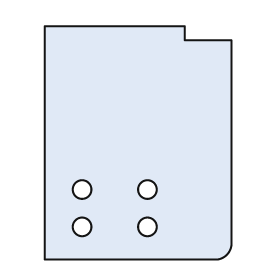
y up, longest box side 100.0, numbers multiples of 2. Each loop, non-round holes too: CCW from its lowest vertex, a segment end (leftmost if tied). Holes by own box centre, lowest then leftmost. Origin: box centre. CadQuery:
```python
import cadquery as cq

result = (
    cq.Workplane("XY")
    .moveTo(-40.0, -50.0)
    .lineTo(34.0, -50.0)
    .threePointArc((38.0, -48.0), (40.0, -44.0))
    .lineTo(40.0, 44.0)
    .lineTo(20.0, 44.0)
    .lineTo(20.0, 50.0)
    .lineTo(-40.0, 50.0)
    .close()
    .moveTo(-24.0, -36.0)
    .circle(4.0)
    .moveTo(4.0, -36.0)
    .circle(4.0)
    .moveTo(-24.0, -20.0)
    .circle(4.0)
    .moveTo(4.0, -20.0)
    .circle(4.0)
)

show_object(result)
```